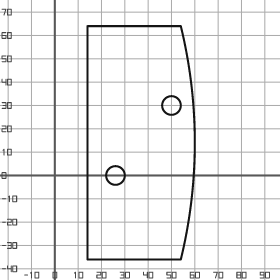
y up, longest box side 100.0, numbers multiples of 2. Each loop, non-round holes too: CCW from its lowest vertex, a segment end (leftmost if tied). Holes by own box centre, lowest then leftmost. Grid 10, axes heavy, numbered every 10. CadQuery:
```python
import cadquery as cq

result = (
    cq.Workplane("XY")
    .moveTo(14.0, -36.0)
    .lineTo(54.0, -36.0)
    .threePointArc((60.0, 14.0), (54.0, 64.0))
    .lineTo(14.0, 64.0)
    .close()
    .moveTo(26.0, 0.0)
    .circle(4.0)
    .moveTo(50.0, 30.0)
    .circle(4.0)
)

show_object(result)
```